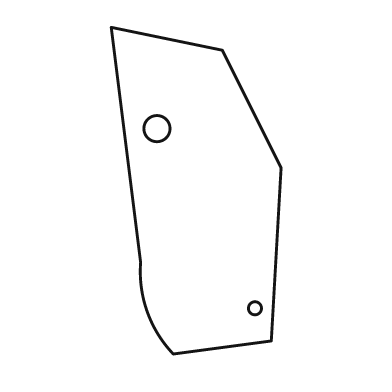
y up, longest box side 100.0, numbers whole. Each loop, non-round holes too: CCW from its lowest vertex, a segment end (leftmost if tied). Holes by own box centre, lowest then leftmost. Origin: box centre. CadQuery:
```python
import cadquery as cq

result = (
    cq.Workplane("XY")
    .moveTo(-7.0, -50.0)
    .lineTo(23.0, -46.0)
    .lineTo(26.0, 7.0)
    .lineTo(8.0, 43.0)
    .lineTo(-26.0, 50.0)
    .lineTo(-17.0, -22.0)
    .threePointArc((-15.0, -37.0), (-7.0, -50.0))
    .close()
    .moveTo(18.0, -36.0)
    .circle(2.0)
    .moveTo(-12.0, 19.0)
    .circle(4.0)
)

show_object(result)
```